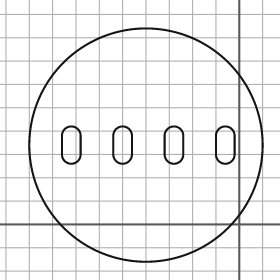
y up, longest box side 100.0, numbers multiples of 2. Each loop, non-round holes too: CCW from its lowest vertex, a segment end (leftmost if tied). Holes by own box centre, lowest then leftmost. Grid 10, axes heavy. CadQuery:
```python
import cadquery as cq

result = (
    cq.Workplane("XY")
    .moveTo(-40.0, 34.0)
    .circle(50.0)
    .moveTo(-76.0, 30.0)
    .threePointArc((-72.0, 26.0), (-68.0, 30.0))
    .lineTo(-68.0, 38.0)
    .threePointArc((-72.0, 42.0), (-76.0, 38.0))
    .close()
    .moveTo(-54.0, 30.0)
    .threePointArc((-50.0, 26.0), (-46.0, 30.0))
    .lineTo(-46.0, 38.0)
    .threePointArc((-50.0, 42.0), (-54.0, 38.0))
    .close()
    .moveTo(-32.0, 30.0)
    .threePointArc((-28.0, 26.0), (-24.0, 30.0))
    .lineTo(-24.0, 38.0)
    .threePointArc((-28.0, 42.0), (-32.0, 38.0))
    .close()
    .moveTo(-10.0, 30.0)
    .threePointArc((-6.0, 26.0), (-2.0, 30.0))
    .lineTo(-2.0, 38.0)
    .threePointArc((-6.0, 42.0), (-10.0, 38.0))
    .close()
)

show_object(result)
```